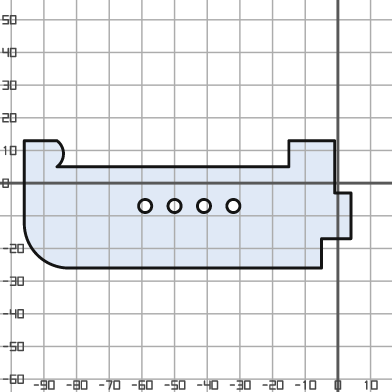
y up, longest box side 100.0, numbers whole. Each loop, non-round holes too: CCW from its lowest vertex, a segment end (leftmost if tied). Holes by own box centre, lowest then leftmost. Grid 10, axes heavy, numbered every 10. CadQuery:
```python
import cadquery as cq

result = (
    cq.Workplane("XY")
    .moveTo(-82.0, -26.0)
    .lineTo(-5.0, -26.0)
    .lineTo(-5.0, -17.0)
    .lineTo(4.0, -17.0)
    .lineTo(4.0, -3.0)
    .lineTo(-1.0, -3.0)
    .lineTo(-1.0, 13.0)
    .lineTo(-15.0, 13.0)
    .lineTo(-15.0, 5.0)
    .lineTo(-86.0, 5.0)
    .threePointArc((-84.0, 9.0), (-86.0, 13.0))
    .lineTo(-96.0, 13.0)
    .lineTo(-96.0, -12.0)
    .threePointArc((-92.0, -22.0), (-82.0, -26.0))
    .close()
    .moveTo(-59.0, -7.0)
    .circle(2.0)
    .moveTo(-50.0, -7.0)
    .circle(2.0)
    .moveTo(-41.0, -7.0)
    .circle(2.0)
    .moveTo(-32.0, -7.0)
    .circle(2.0)
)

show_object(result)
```